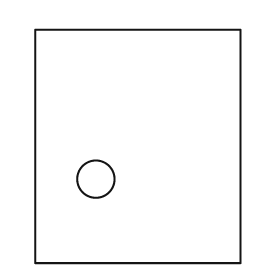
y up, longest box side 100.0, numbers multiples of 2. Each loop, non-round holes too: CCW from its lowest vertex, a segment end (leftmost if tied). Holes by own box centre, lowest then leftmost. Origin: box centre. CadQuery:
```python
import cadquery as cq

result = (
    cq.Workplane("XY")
    .moveTo(-44.0, -50.0)
    .lineTo(44.0, -50.0)
    .lineTo(44.0, 50.0)
    .lineTo(-44.0, 50.0)
    .close()
    .moveTo(-18.0, -14.0)
    .circle(8.0)
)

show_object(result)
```